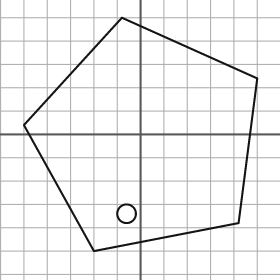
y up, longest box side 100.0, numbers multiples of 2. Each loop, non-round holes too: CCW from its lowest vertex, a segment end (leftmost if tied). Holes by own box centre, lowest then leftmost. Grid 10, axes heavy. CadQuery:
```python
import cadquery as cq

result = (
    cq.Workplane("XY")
    .moveTo(-20.0, -50.0)
    .lineTo(42.0, -38.0)
    .lineTo(50.0, 24.0)
    .lineTo(-8.0, 50.0)
    .lineTo(-50.0, 4.0)
    .close()
    .moveTo(-6.0, -34.0)
    .circle(4.0)
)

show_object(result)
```